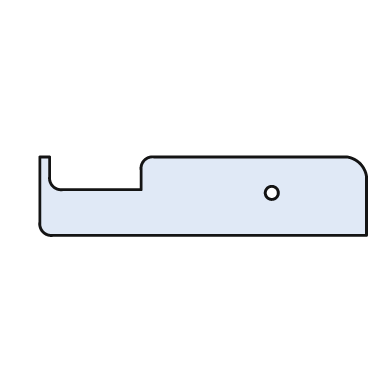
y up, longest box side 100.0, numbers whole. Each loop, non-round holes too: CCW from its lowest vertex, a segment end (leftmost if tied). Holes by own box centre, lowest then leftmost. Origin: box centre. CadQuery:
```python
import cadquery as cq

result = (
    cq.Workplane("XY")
    .moveTo(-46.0, -12.0)
    .lineTo(50.0, -12.0)
    .lineTo(50.0, 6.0)
    .threePointArc((48.0, 10.0), (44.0, 12.0))
    .lineTo(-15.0, 12.0)
    .threePointArc((-18.0, 11.0), (-19.0, 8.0))
    .lineTo(-19.0, 2.0)
    .lineTo(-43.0, 2.0)
    .threePointArc((-46.0, 3.0), (-47.0, 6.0))
    .lineTo(-47.0, 12.0)
    .lineTo(-50.0, 12.0)
    .lineTo(-50.0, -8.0)
    .threePointArc((-49.0, -11.0), (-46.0, -12.0))
    .close()
    .moveTo(21.0, 1.0)
    .circle(2.0)
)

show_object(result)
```